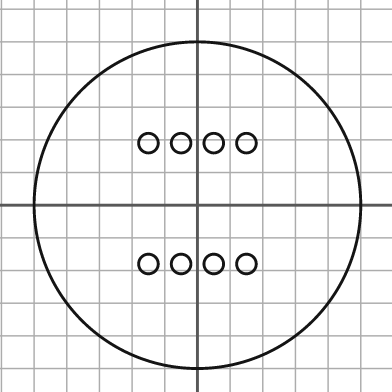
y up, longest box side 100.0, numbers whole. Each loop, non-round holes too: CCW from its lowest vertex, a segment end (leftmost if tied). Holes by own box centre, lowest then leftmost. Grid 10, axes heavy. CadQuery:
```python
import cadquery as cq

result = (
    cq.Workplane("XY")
    .moveTo(0.0, 0.0)
    .circle(50.0)
    .moveTo(-15.0, -18.0)
    .circle(3.0)
    .moveTo(-5.0, -18.0)
    .circle(3.0)
    .moveTo(5.0, -18.0)
    .circle(3.0)
    .moveTo(15.0, -18.0)
    .circle(3.0)
    .moveTo(-15.0, 19.0)
    .circle(3.0)
    .moveTo(-5.0, 19.0)
    .circle(3.0)
    .moveTo(5.0, 19.0)
    .circle(3.0)
    .moveTo(15.0, 19.0)
    .circle(3.0)
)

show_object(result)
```